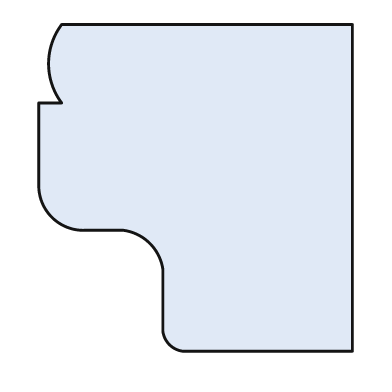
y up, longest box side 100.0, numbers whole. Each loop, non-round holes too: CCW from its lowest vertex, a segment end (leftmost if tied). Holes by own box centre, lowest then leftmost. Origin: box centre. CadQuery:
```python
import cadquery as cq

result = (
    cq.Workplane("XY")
    .moveTo(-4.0, -50.0)
    .lineTo(48.0, -50.0)
    .lineTo(48.0, 50.0)
    .lineTo(-41.0, 50.0)
    .threePointArc((-45.0, 38.0), (-41.0, 26.0))
    .lineTo(-48.0, 26.0)
    .lineTo(-48.0, 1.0)
    .threePointArc((-44.0, -9.0), (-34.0, -13.0))
    .lineTo(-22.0, -13.0)
    .threePointArc((-14.0, -17.0), (-10.0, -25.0))
    .lineTo(-10.0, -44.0)
    .threePointArc((-8.0, -48.0), (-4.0, -50.0))
    .close()
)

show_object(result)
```